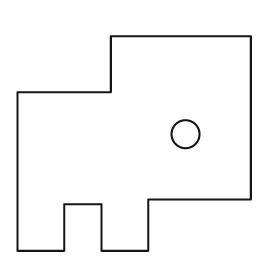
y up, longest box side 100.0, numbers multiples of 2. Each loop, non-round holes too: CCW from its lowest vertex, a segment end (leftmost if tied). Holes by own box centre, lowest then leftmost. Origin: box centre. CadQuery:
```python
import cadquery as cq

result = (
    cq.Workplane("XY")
    .moveTo(-50.0, -46.0)
    .lineTo(-30.0, -46.0)
    .lineTo(-30.0, -26.0)
    .lineTo(-14.0, -26.0)
    .lineTo(-14.0, -46.0)
    .lineTo(6.0, -46.0)
    .lineTo(6.0, -24.0)
    .lineTo(50.0, -24.0)
    .lineTo(50.0, 46.0)
    .lineTo(-10.0, 46.0)
    .lineTo(-10.0, 22.0)
    .lineTo(-50.0, 22.0)
    .close()
    .moveTo(22.0, 4.0)
    .circle(6.0)
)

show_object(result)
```